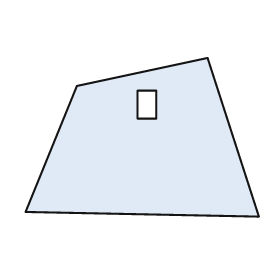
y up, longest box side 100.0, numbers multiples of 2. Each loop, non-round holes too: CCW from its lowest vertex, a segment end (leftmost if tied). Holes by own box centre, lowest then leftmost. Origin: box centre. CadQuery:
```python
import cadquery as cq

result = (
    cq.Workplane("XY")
    .moveTo(50.0, -34.0)
    .lineTo(28.0, 34.0)
    .lineTo(-28.0, 22.0)
    .lineTo(-50.0, -32.0)
    .close()
    .moveTo(-2.0, 8.0)
    .lineTo(6.0, 8.0)
    .lineTo(6.0, 20.0)
    .lineTo(-2.0, 20.0)
    .close()
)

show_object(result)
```